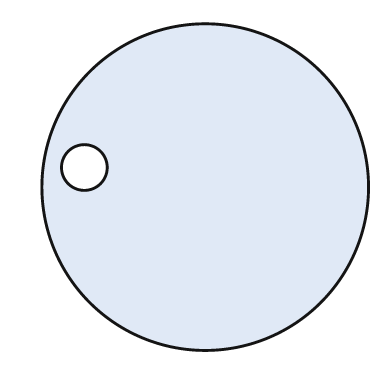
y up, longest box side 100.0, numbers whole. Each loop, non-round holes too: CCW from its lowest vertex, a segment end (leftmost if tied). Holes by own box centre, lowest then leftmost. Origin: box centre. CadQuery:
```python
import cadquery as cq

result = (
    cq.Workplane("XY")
    .moveTo(0.0, 0.0)
    .circle(50.0)
    .moveTo(-37.0, 6.0)
    .circle(7.0)
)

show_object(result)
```